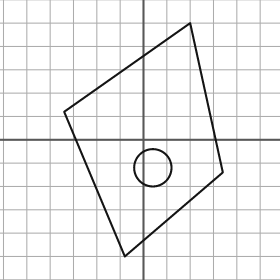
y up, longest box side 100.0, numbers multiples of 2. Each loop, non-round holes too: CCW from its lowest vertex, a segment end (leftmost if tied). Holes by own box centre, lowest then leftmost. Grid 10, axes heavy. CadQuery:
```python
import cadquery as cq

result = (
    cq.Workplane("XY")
    .moveTo(-8.0, -50.0)
    .lineTo(34.0, -14.0)
    .lineTo(20.0, 50.0)
    .lineTo(-34.0, 12.0)
    .close()
    .moveTo(4.0, -12.0)
    .circle(8.0)
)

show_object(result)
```